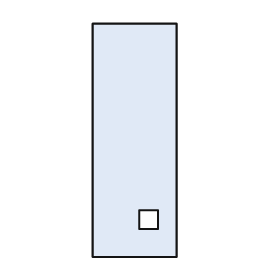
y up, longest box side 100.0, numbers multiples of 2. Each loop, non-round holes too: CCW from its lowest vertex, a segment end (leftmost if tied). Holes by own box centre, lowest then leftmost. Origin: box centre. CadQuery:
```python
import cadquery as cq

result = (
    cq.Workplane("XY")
    .moveTo(-18.0, -50.0)
    .lineTo(18.0, -50.0)
    .lineTo(18.0, 50.0)
    .lineTo(-18.0, 50.0)
    .close()
    .moveTo(2.0, -38.0)
    .lineTo(10.0, -38.0)
    .lineTo(10.0, -30.0)
    .lineTo(2.0, -30.0)
    .close()
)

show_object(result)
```